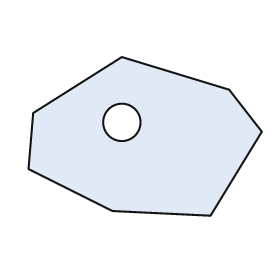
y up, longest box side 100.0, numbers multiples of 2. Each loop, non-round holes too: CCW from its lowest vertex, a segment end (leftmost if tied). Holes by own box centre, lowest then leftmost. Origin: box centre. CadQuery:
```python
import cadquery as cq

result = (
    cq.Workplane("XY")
    .moveTo(28.0, -34.0)
    .lineTo(50.0, 2.0)
    .lineTo(36.0, 20.0)
    .lineTo(-10.0, 34.0)
    .lineTo(-48.0, 10.0)
    .lineTo(-50.0, -14.0)
    .lineTo(-14.0, -32.0)
    .close()
    .moveTo(-10.0, 6.0)
    .circle(8.0)
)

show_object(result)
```